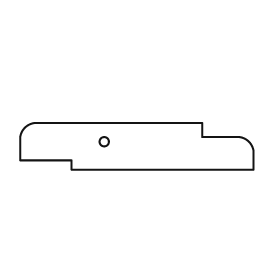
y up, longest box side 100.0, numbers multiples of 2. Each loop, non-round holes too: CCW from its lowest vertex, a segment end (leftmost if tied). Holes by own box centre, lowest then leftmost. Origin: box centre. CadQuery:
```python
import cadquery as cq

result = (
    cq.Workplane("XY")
    .moveTo(-28.0, -10.0)
    .lineTo(50.0, -10.0)
    .lineTo(50.0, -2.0)
    .threePointArc((48.0, 2.0), (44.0, 4.0))
    .lineTo(28.0, 4.0)
    .lineTo(28.0, 10.0)
    .lineTo(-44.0, 10.0)
    .threePointArc((-48.0, 8.0), (-50.0, 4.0))
    .lineTo(-50.0, -6.0)
    .lineTo(-28.0, -6.0)
    .close()
    .moveTo(-14.0, 2.0)
    .circle(2.0)
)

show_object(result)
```